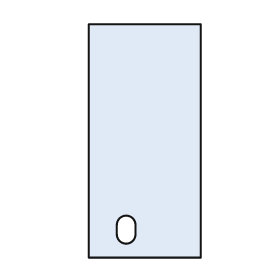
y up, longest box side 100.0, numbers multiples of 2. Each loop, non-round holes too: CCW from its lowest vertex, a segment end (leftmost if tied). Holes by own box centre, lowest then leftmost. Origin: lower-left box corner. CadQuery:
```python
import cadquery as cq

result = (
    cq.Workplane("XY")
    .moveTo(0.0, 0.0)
    .lineTo(48.0, 0.0)
    .lineTo(48.0, 100.0)
    .lineTo(0.0, 100.0)
    .close()
    .moveTo(12.0, 10.0)
    .threePointArc((16.0, 6.0), (20.0, 10.0))
    .lineTo(20.0, 14.0)
    .threePointArc((16.0, 18.0), (12.0, 14.0))
    .close()
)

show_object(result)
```